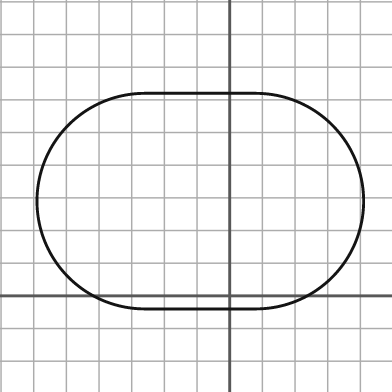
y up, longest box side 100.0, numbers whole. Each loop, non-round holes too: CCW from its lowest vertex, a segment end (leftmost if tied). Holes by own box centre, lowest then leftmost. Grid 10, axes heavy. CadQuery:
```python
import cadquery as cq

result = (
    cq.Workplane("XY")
    .moveTo(-26.0, -4.0)
    .lineTo(8.0, -4.0)
    .threePointArc((41.0, 29.0), (8.0, 62.0))
    .lineTo(-26.0, 62.0)
    .threePointArc((-59.0, 29.0), (-26.0, -4.0))
    .close()
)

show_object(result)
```